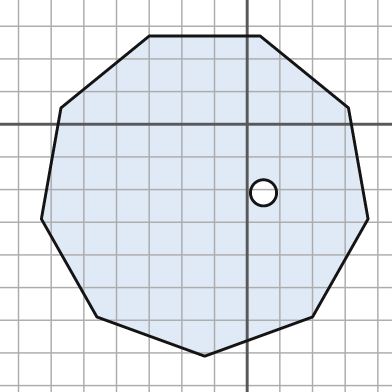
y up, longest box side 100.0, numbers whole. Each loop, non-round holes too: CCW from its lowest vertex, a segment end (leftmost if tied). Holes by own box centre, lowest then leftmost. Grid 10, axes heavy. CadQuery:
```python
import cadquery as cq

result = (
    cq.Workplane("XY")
    .moveTo(-13.0, -71.0)
    .lineTo(20.0, -59.0)
    .lineTo(37.0, -29.0)
    .lineTo(31.0, 5.0)
    .lineTo(4.0, 27.0)
    .lineTo(-30.0, 27.0)
    .lineTo(-57.0, 5.0)
    .lineTo(-63.0, -29.0)
    .lineTo(-46.0, -59.0)
    .close()
    .moveTo(5.0, -21.0)
    .circle(4.0)
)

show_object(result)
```